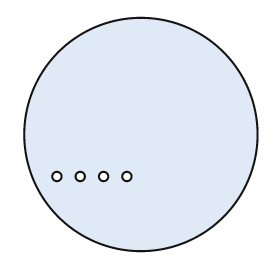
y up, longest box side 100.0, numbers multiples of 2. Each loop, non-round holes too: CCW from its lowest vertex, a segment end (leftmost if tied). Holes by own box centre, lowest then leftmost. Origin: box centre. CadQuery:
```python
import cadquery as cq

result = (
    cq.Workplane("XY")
    .moveTo(0.0, 0.0)
    .circle(50.0)
    .moveTo(-36.0, -18.0)
    .circle(2.0)
    .moveTo(-26.0, -18.0)
    .circle(2.0)
    .moveTo(-16.0, -18.0)
    .circle(2.0)
    .moveTo(-6.0, -18.0)
    .circle(2.0)
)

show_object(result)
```